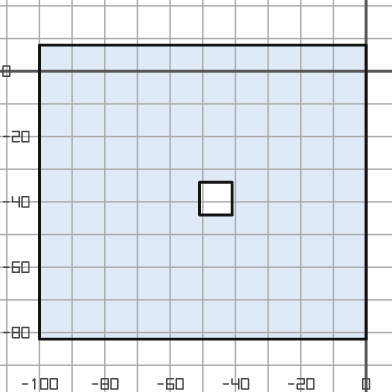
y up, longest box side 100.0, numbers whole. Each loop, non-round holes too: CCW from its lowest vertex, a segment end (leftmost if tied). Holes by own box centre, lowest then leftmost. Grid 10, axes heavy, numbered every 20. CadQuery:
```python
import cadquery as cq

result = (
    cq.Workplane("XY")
    .moveTo(-100.0, -82.0)
    .lineTo(0.0, -82.0)
    .lineTo(0.0, 8.0)
    .lineTo(-100.0, 8.0)
    .close()
    .moveTo(-51.0, -44.0)
    .lineTo(-41.0, -44.0)
    .lineTo(-41.0, -34.0)
    .lineTo(-51.0, -34.0)
    .close()
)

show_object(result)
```